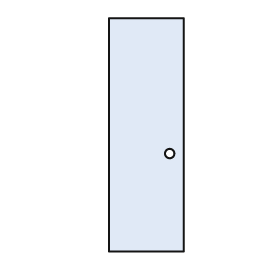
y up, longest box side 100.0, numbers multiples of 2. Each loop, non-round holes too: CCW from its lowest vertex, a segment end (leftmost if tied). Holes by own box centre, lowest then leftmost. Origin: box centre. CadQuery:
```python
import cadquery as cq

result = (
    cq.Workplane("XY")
    .moveTo(-16.0, -50.0)
    .lineTo(16.0, -50.0)
    .lineTo(16.0, 50.0)
    .lineTo(-16.0, 50.0)
    .close()
    .moveTo(10.0, -8.0)
    .circle(2.0)
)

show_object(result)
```